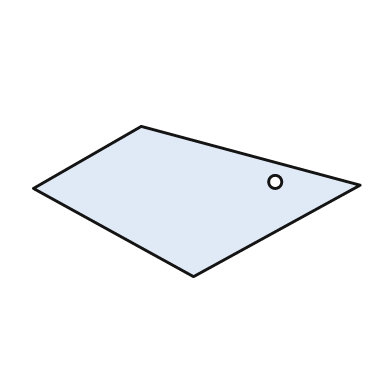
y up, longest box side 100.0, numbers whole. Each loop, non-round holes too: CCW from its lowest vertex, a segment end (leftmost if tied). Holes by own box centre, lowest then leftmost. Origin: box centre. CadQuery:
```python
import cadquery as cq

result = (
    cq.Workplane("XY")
    .moveTo(-1.0, -23.0)
    .lineTo(50.0, 5.0)
    .lineTo(-17.0, 23.0)
    .lineTo(-50.0, 4.0)
    .close()
    .moveTo(24.0, 6.0)
    .circle(2.0)
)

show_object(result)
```